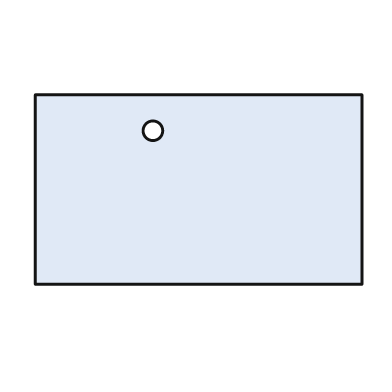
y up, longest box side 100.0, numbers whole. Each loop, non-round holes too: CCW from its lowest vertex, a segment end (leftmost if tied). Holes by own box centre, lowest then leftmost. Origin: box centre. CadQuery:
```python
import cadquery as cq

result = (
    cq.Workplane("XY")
    .moveTo(-50.0, -29.0)
    .lineTo(50.0, -29.0)
    .lineTo(50.0, 29.0)
    .lineTo(-50.0, 29.0)
    .close()
    .moveTo(-14.0, 18.0)
    .circle(3.0)
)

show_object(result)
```